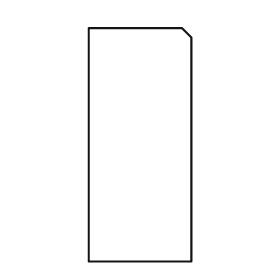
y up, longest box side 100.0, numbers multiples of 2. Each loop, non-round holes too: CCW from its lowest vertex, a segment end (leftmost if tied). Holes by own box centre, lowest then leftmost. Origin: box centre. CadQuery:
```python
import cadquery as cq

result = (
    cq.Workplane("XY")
    .moveTo(-22.0, -50.0)
    .lineTo(22.0, -50.0)
    .lineTo(22.0, 46.0)
    .lineTo(18.0, 50.0)
    .lineTo(-22.0, 50.0)
    .close()
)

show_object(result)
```